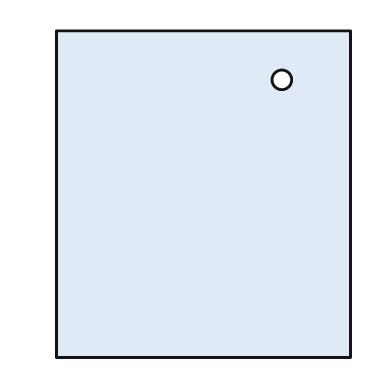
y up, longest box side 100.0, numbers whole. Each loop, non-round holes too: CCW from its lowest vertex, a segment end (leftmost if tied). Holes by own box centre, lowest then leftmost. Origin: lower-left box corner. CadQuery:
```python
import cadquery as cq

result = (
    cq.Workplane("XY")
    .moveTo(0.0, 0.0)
    .lineTo(90.0, 0.0)
    .lineTo(90.0, 100.0)
    .lineTo(0.0, 100.0)
    .close()
    .moveTo(69.0, 85.0)
    .circle(3.0)
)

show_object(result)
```